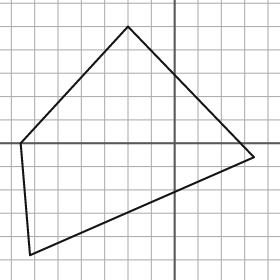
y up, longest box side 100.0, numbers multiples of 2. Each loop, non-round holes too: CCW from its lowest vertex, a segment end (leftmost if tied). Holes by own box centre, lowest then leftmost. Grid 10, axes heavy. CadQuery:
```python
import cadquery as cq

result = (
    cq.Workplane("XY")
    .moveTo(-62.0, -48.0)
    .lineTo(34.0, -6.0)
    .lineTo(-20.0, 50.0)
    .lineTo(-66.0, 0.0)
    .close()
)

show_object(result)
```